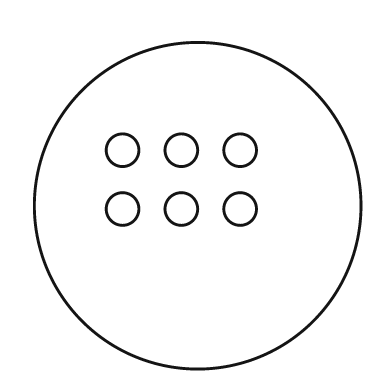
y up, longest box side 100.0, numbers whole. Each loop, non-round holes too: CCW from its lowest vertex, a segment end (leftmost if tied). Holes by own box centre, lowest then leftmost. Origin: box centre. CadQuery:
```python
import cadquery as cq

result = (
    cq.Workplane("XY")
    .moveTo(0.0, 0.0)
    .circle(50.0)
    .moveTo(-23.0, -1.0)
    .circle(5.0)
    .moveTo(-5.0, -1.0)
    .circle(5.0)
    .moveTo(13.0, -1.0)
    .circle(5.0)
    .moveTo(-23.0, 17.0)
    .circle(5.0)
    .moveTo(-5.0, 17.0)
    .circle(5.0)
    .moveTo(13.0, 17.0)
    .circle(5.0)
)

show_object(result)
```